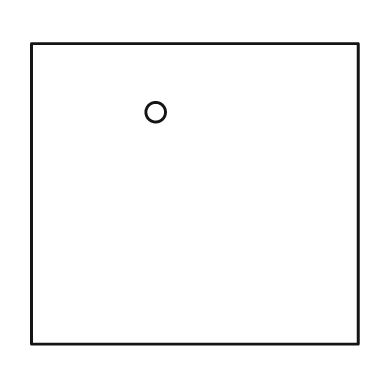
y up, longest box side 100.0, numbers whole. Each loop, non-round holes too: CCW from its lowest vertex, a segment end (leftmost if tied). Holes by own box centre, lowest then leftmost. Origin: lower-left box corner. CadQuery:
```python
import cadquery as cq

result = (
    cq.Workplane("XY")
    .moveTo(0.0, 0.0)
    .lineTo(100.0, 0.0)
    .lineTo(100.0, 92.0)
    .lineTo(0.0, 92.0)
    .close()
    .moveTo(38.0, 71.0)
    .circle(3.0)
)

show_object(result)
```